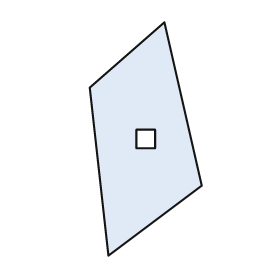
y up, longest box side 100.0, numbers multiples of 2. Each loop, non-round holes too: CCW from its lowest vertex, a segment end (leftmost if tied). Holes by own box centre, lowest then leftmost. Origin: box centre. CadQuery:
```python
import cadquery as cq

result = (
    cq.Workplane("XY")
    .moveTo(-16.0, -50.0)
    .lineTo(24.0, -20.0)
    .lineTo(8.0, 50.0)
    .lineTo(-24.0, 22.0)
    .close()
    .moveTo(-4.0, -4.0)
    .lineTo(4.0, -4.0)
    .lineTo(4.0, 4.0)
    .lineTo(-4.0, 4.0)
    .close()
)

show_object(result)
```